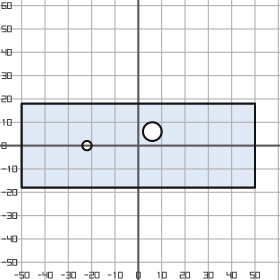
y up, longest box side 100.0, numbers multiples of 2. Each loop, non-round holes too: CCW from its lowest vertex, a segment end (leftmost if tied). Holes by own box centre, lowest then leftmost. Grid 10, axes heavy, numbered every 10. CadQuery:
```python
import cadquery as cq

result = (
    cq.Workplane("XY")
    .moveTo(-50.0, -18.0)
    .lineTo(50.0, -18.0)
    .lineTo(50.0, 18.0)
    .lineTo(-50.0, 18.0)
    .close()
    .moveTo(-22.0, 0.0)
    .circle(2.0)
    .moveTo(6.0, 6.0)
    .circle(4.0)
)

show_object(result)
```